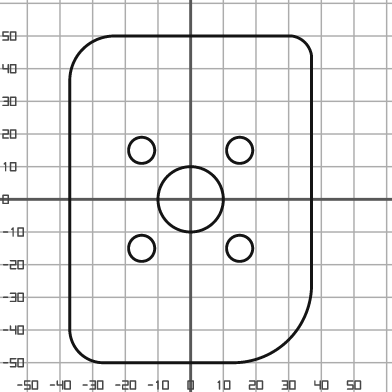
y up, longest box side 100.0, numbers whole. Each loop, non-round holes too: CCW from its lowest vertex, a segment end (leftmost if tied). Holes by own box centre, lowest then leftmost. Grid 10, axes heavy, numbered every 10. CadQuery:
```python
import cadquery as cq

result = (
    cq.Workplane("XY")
    .moveTo(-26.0, -50.0)
    .lineTo(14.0, -50.0)
    .threePointArc((30.0, -43.0), (37.0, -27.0))
    .lineTo(37.0, 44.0)
    .threePointArc((35.0, 48.0), (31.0, 50.0))
    .lineTo(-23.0, 50.0)
    .threePointArc((-33.0, 46.0), (-37.0, 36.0))
    .lineTo(-37.0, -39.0)
    .threePointArc((-34.0, -47.0), (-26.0, -50.0))
    .close()
    .moveTo(-15.0, -15.0)
    .circle(4.0)
    .moveTo(15.0, -15.0)
    .circle(4.0)
    .moveTo(0.0, 0.0)
    .circle(10.0)
    .moveTo(-15.0, 15.0)
    .circle(4.0)
    .moveTo(15.0, 15.0)
    .circle(4.0)
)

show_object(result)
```